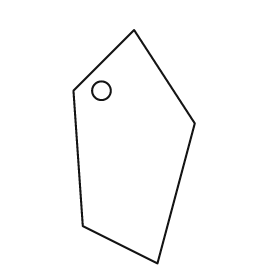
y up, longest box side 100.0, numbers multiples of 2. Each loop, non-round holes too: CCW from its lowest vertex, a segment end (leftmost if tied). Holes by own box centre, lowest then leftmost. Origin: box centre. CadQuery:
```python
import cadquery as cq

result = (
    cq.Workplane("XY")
    .moveTo(10.0, -50.0)
    .lineTo(26.0, 10.0)
    .lineTo(0.0, 50.0)
    .lineTo(-26.0, 24.0)
    .lineTo(-22.0, -34.0)
    .close()
    .moveTo(-14.0, 24.0)
    .circle(4.0)
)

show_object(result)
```